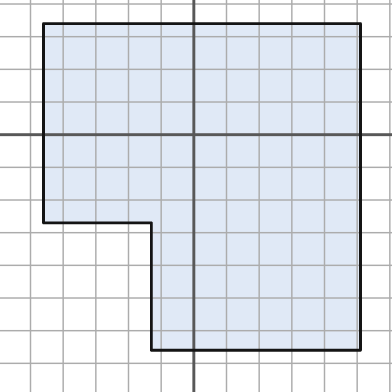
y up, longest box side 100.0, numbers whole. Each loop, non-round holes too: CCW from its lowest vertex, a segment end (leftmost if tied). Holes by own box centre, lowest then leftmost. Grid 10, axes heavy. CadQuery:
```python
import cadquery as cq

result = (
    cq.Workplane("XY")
    .moveTo(-13.0, -66.0)
    .lineTo(51.0, -66.0)
    .lineTo(51.0, 34.0)
    .lineTo(-46.0, 34.0)
    .lineTo(-46.0, -27.0)
    .lineTo(-13.0, -27.0)
    .close()
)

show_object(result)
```